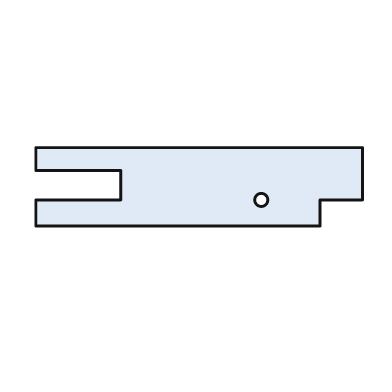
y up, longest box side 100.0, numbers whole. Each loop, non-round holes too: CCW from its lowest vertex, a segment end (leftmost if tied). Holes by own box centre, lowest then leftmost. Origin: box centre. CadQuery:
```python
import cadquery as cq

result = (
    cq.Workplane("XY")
    .moveTo(-50.0, -12.0)
    .lineTo(37.0, -12.0)
    .lineTo(37.0, -4.0)
    .lineTo(50.0, -4.0)
    .lineTo(50.0, 12.0)
    .lineTo(-50.0, 12.0)
    .lineTo(-50.0, 5.0)
    .lineTo(-24.0, 5.0)
    .lineTo(-24.0, -4.0)
    .lineTo(-50.0, -4.0)
    .close()
    .moveTo(19.0, -4.0)
    .circle(2.0)
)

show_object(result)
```